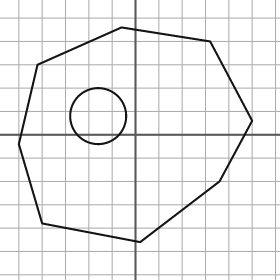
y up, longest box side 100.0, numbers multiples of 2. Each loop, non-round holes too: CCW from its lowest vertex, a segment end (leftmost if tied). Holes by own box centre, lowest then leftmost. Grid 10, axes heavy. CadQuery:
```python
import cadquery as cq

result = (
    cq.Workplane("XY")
    .moveTo(2.0, -46.0)
    .lineTo(36.0, -20.0)
    .lineTo(50.0, 6.0)
    .lineTo(32.0, 40.0)
    .lineTo(-6.0, 46.0)
    .lineTo(-42.0, 30.0)
    .lineTo(-50.0, -4.0)
    .lineTo(-40.0, -38.0)
    .close()
    .moveTo(-16.0, 8.0)
    .circle(12.0)
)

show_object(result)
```